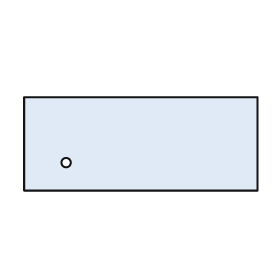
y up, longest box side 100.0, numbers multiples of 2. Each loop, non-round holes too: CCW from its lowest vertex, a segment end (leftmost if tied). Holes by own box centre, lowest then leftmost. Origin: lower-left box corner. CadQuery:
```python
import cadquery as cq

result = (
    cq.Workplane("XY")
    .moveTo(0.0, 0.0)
    .lineTo(100.0, 0.0)
    .lineTo(100.0, 40.0)
    .lineTo(0.0, 40.0)
    .close()
    .moveTo(18.0, 12.0)
    .circle(2.0)
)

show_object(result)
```